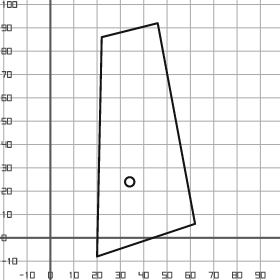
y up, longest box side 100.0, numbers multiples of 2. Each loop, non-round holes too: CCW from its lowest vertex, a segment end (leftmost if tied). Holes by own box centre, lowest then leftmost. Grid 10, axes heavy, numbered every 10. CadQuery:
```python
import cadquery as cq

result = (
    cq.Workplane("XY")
    .moveTo(20.0, -8.0)
    .lineTo(62.0, 6.0)
    .lineTo(46.0, 92.0)
    .lineTo(22.0, 86.0)
    .close()
    .moveTo(34.0, 24.0)
    .circle(2.0)
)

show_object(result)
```